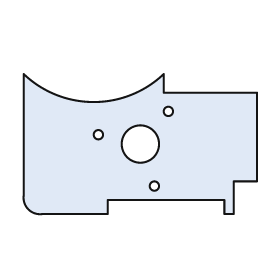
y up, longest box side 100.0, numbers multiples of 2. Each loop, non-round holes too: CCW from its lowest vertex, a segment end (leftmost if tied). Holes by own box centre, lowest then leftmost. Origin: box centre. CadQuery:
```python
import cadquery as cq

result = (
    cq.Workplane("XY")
    .moveTo(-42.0, -30.0)
    .lineTo(-14.0, -30.0)
    .lineTo(-14.0, -24.0)
    .lineTo(36.0, -24.0)
    .lineTo(36.0, -30.0)
    .lineTo(40.0, -30.0)
    .lineTo(40.0, -16.0)
    .lineTo(50.0, -16.0)
    .lineTo(50.0, 22.0)
    .lineTo(10.0, 22.0)
    .lineTo(10.0, 30.0)
    .threePointArc((-20.0, 18.0), (-50.0, 30.0))
    .lineTo(-50.0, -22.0)
    .threePointArc((-48.0, -28.0), (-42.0, -30.0))
    .close()
    .moveTo(6.0, -18.0)
    .circle(2.0)
    .moveTo(0.0, 0.0)
    .circle(8.0)
    .moveTo(-18.0, 4.0)
    .circle(2.0)
    .moveTo(12.0, 14.0)
    .circle(2.0)
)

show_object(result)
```